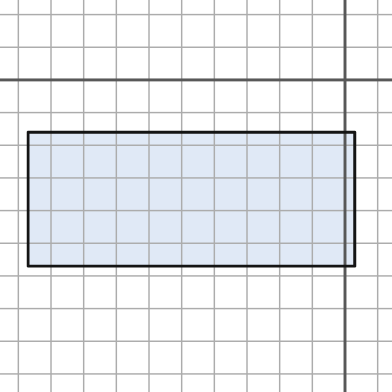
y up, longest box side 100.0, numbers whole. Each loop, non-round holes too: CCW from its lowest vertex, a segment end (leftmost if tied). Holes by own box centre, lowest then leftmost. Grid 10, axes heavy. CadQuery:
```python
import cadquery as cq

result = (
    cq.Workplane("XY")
    .moveTo(-97.0, -57.0)
    .lineTo(3.0, -57.0)
    .lineTo(3.0, -16.0)
    .lineTo(-97.0, -16.0)
    .close()
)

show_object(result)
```